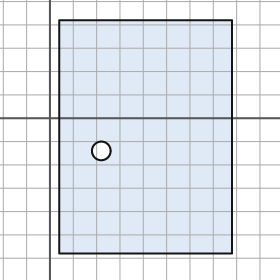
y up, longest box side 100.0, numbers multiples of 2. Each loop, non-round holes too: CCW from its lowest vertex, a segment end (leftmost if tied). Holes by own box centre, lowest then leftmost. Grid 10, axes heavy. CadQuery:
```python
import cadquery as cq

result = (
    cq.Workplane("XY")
    .moveTo(4.0, -58.0)
    .lineTo(78.0, -58.0)
    .lineTo(78.0, 42.0)
    .lineTo(4.0, 42.0)
    .close()
    .moveTo(22.0, -14.0)
    .circle(4.0)
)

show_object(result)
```